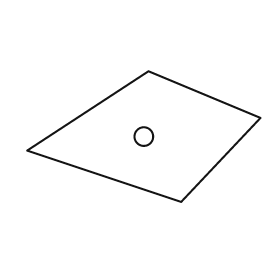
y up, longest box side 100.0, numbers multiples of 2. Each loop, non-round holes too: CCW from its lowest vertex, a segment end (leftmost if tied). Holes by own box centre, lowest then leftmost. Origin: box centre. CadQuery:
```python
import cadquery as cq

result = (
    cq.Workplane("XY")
    .moveTo(16.0, -28.0)
    .lineTo(50.0, 8.0)
    .lineTo(2.0, 28.0)
    .lineTo(-50.0, -6.0)
    .close()
    .moveTo(0.0, 0.0)
    .circle(4.0)
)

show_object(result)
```